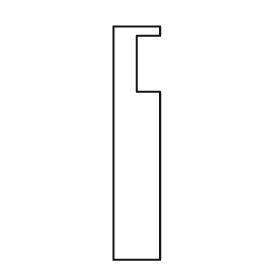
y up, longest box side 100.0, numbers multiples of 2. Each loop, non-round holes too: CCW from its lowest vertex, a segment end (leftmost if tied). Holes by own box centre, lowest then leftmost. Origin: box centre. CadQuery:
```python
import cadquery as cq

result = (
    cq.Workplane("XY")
    .moveTo(-10.0, -50.0)
    .lineTo(10.0, -50.0)
    .lineTo(10.0, 22.0)
    .lineTo(0.0, 22.0)
    .lineTo(0.0, 46.0)
    .lineTo(10.0, 46.0)
    .lineTo(10.0, 50.0)
    .lineTo(-10.0, 50.0)
    .close()
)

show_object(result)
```